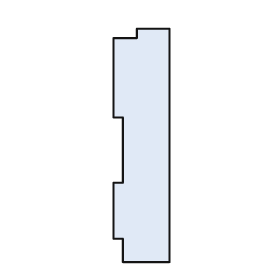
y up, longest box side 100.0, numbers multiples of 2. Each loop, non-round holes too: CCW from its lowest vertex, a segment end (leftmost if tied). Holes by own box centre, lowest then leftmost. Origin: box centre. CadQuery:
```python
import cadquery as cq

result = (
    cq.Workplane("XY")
    .moveTo(-8.0, -50.0)
    .lineTo(12.0, -50.0)
    .lineTo(12.0, 50.0)
    .lineTo(-2.0, 50.0)
    .lineTo(-2.0, 46.0)
    .lineTo(-12.0, 46.0)
    .lineTo(-12.0, 12.0)
    .lineTo(-8.0, 12.0)
    .lineTo(-8.0, -16.0)
    .lineTo(-12.0, -16.0)
    .lineTo(-12.0, -40.0)
    .lineTo(-8.0, -40.0)
    .close()
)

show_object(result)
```